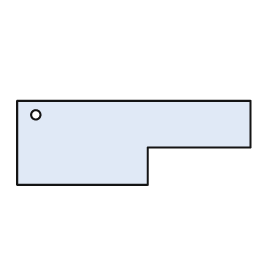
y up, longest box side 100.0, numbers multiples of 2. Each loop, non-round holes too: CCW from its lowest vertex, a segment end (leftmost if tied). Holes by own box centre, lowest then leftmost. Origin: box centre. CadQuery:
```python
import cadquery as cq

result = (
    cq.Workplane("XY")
    .moveTo(-50.0, -18.0)
    .lineTo(6.0, -18.0)
    .lineTo(6.0, -2.0)
    .lineTo(50.0, -2.0)
    .lineTo(50.0, 18.0)
    .lineTo(-50.0, 18.0)
    .close()
    .moveTo(-42.0, 12.0)
    .circle(2.0)
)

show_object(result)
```